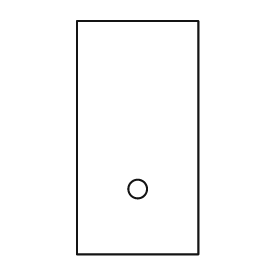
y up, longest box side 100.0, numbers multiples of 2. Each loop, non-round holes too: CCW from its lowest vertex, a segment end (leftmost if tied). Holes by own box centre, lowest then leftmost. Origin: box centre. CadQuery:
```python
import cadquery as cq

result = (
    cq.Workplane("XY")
    .moveTo(-26.0, -50.0)
    .lineTo(26.0, -50.0)
    .lineTo(26.0, 50.0)
    .lineTo(-26.0, 50.0)
    .close()
    .moveTo(0.0, -22.0)
    .circle(4.0)
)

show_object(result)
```